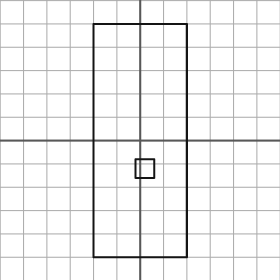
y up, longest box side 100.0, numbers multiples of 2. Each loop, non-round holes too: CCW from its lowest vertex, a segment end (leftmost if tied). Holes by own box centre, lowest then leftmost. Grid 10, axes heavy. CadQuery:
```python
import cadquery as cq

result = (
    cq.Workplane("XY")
    .moveTo(-20.0, -50.0)
    .lineTo(20.0, -50.0)
    .lineTo(20.0, 50.0)
    .lineTo(-20.0, 50.0)
    .close()
    .moveTo(-2.0, -16.0)
    .lineTo(6.0, -16.0)
    .lineTo(6.0, -8.0)
    .lineTo(-2.0, -8.0)
    .close()
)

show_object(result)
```